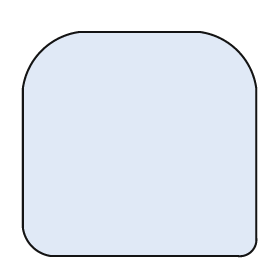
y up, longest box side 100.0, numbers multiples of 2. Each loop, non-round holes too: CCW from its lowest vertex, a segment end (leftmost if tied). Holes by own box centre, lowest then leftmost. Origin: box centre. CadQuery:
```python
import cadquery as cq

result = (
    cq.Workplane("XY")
    .moveTo(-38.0, -48.0)
    .lineTo(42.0, -48.0)
    .threePointArc((48.0, -46.0), (50.0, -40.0))
    .lineTo(50.0, 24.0)
    .threePointArc((42.0, 40.0), (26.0, 48.0))
    .lineTo(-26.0, 48.0)
    .threePointArc((-42.0, 40.0), (-50.0, 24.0))
    .lineTo(-50.0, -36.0)
    .threePointArc((-46.0, -44.0), (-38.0, -48.0))
    .close()
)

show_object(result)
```